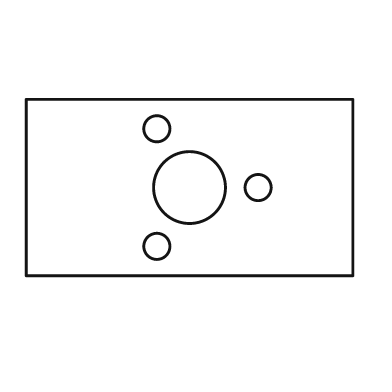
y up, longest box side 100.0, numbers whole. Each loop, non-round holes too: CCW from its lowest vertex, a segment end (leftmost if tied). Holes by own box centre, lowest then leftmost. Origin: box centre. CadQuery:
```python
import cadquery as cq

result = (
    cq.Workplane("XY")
    .moveTo(-50.0, -27.0)
    .lineTo(50.0, -27.0)
    .lineTo(50.0, 27.0)
    .lineTo(-50.0, 27.0)
    .close()
    .moveTo(-10.0, -18.0)
    .circle(4.0)
    .moveTo(0.0, 0.0)
    .circle(11.0)
    .moveTo(21.0, 0.0)
    .circle(4.0)
    .moveTo(-10.0, 18.0)
    .circle(4.0)
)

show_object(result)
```